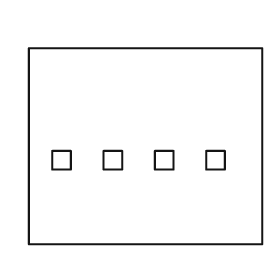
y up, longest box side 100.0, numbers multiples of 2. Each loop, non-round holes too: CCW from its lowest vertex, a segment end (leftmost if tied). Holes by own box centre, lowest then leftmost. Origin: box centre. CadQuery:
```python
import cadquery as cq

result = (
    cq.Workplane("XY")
    .moveTo(-50.0, -42.0)
    .lineTo(50.0, -42.0)
    .lineTo(50.0, 42.0)
    .lineTo(-50.0, 42.0)
    .close()
    .moveTo(-40.0, -10.0)
    .lineTo(-32.0, -10.0)
    .lineTo(-32.0, -2.0)
    .lineTo(-40.0, -2.0)
    .close()
    .moveTo(-18.0, -10.0)
    .lineTo(-10.0, -10.0)
    .lineTo(-10.0, -2.0)
    .lineTo(-18.0, -2.0)
    .close()
    .moveTo(4.0, -10.0)
    .lineTo(12.0, -10.0)
    .lineTo(12.0, -2.0)
    .lineTo(4.0, -2.0)
    .close()
    .moveTo(26.0, -10.0)
    .lineTo(34.0, -10.0)
    .lineTo(34.0, -2.0)
    .lineTo(26.0, -2.0)
    .close()
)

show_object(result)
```